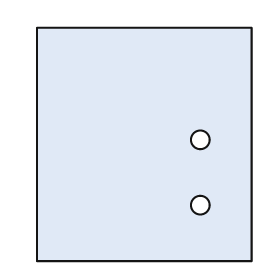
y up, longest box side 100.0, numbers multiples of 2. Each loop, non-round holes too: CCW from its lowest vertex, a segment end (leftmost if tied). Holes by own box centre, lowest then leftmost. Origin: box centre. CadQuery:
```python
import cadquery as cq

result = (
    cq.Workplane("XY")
    .moveTo(-46.0, -50.0)
    .lineTo(46.0, -50.0)
    .lineTo(46.0, 50.0)
    .lineTo(-46.0, 50.0)
    .close()
    .moveTo(24.0, -26.0)
    .circle(4.0)
    .moveTo(24.0, 2.0)
    .circle(4.0)
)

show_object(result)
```